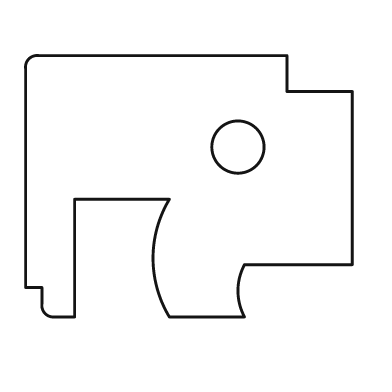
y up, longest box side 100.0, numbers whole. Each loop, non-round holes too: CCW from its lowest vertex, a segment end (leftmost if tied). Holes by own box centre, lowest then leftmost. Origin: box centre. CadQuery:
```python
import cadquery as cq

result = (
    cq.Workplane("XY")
    .moveTo(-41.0, -40.0)
    .lineTo(-35.0, -40.0)
    .lineTo(-35.0, -4.0)
    .lineTo(-6.0, -4.0)
    .threePointArc((-11.0, -22.0), (-6.0, -40.0))
    .lineTo(17.0, -40.0)
    .threePointArc((15.0, -32.0), (17.0, -24.0))
    .lineTo(50.0, -24.0)
    .lineTo(50.0, 29.0)
    .lineTo(30.0, 29.0)
    .lineTo(30.0, 40.0)
    .lineTo(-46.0, 40.0)
    .threePointArc((-49.0, 39.0), (-50.0, 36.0))
    .lineTo(-50.0, -31.0)
    .lineTo(-45.0, -31.0)
    .lineTo(-45.0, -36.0)
    .threePointArc((-44.0, -39.0), (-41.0, -40.0))
    .close()
    .moveTo(15.0, 12.0)
    .circle(8.0)
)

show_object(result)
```